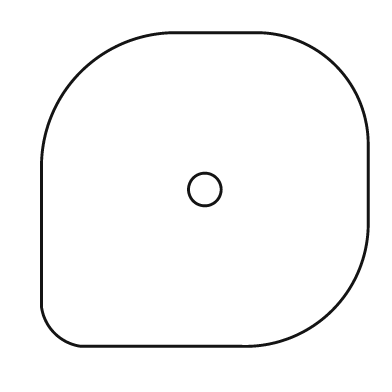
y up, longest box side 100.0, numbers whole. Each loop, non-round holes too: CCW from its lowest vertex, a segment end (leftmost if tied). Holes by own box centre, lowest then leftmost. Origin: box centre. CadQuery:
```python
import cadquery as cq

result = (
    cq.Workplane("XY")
    .moveTo(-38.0, -48.0)
    .lineTo(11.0, -48.0)
    .threePointArc((39.0, -37.0), (50.0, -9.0))
    .lineTo(50.0, 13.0)
    .threePointArc((40.0, 38.0), (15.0, 48.0))
    .lineTo(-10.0, 48.0)
    .threePointArc((-38.0, 36.0), (-50.0, 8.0))
    .lineTo(-50.0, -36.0)
    .threePointArc((-46.0, -44.0), (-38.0, -48.0))
    .close()
    .moveTo(0.0, 0.0)
    .circle(5.0)
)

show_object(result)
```